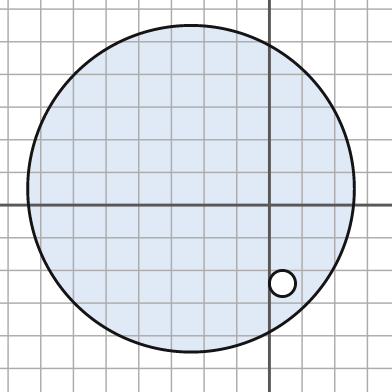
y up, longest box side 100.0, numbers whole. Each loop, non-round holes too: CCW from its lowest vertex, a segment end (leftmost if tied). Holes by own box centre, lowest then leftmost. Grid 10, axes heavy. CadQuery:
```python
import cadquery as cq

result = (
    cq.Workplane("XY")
    .moveTo(-24.0, 5.0)
    .circle(50.0)
    .moveTo(4.0, -24.0)
    .circle(4.0)
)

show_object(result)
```